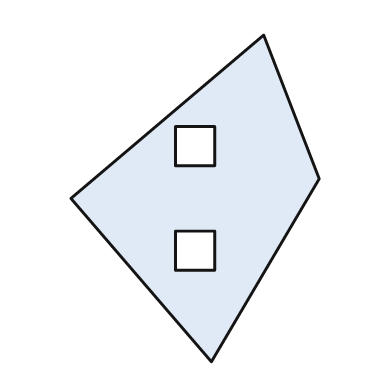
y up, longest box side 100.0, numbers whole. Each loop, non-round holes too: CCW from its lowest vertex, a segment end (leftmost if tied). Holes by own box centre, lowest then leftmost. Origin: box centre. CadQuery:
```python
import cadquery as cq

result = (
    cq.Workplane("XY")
    .moveTo(5.0, -50.0)
    .lineTo(38.0, 6.0)
    .lineTo(21.0, 50.0)
    .lineTo(-38.0, 0.0)
    .close()
    .moveTo(-6.0, -22.0)
    .lineTo(6.0, -22.0)
    .lineTo(6.0, -10.0)
    .lineTo(-6.0, -10.0)
    .close()
    .moveTo(-6.0, 10.0)
    .lineTo(6.0, 10.0)
    .lineTo(6.0, 22.0)
    .lineTo(-6.0, 22.0)
    .close()
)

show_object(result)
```